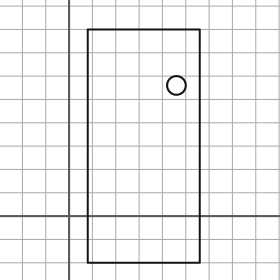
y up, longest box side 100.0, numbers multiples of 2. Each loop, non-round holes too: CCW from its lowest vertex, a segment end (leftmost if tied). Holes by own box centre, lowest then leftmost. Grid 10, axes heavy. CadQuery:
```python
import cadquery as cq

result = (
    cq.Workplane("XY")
    .moveTo(8.0, -20.0)
    .lineTo(56.0, -20.0)
    .lineTo(56.0, 80.0)
    .lineTo(8.0, 80.0)
    .close()
    .moveTo(46.0, 56.0)
    .circle(4.0)
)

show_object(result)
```